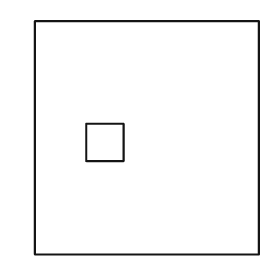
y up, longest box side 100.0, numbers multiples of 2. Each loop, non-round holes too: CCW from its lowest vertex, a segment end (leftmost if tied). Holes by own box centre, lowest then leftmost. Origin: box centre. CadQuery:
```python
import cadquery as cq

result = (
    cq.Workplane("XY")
    .moveTo(-48.0, -50.0)
    .lineTo(48.0, -50.0)
    .lineTo(48.0, 50.0)
    .lineTo(-48.0, 50.0)
    .close()
    .moveTo(-26.0, -10.0)
    .lineTo(-10.0, -10.0)
    .lineTo(-10.0, 6.0)
    .lineTo(-26.0, 6.0)
    .close()
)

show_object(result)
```